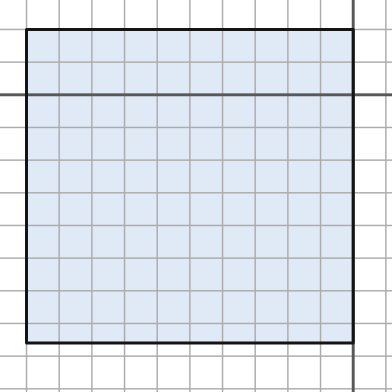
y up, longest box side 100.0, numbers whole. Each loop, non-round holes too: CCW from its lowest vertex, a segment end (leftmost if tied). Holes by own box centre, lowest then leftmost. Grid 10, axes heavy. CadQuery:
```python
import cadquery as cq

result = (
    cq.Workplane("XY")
    .moveTo(-100.0, -76.0)
    .lineTo(0.0, -76.0)
    .lineTo(0.0, 20.0)
    .lineTo(-100.0, 20.0)
    .close()
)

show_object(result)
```